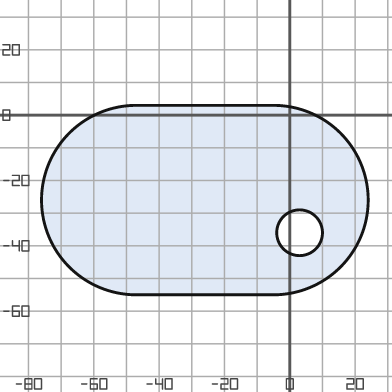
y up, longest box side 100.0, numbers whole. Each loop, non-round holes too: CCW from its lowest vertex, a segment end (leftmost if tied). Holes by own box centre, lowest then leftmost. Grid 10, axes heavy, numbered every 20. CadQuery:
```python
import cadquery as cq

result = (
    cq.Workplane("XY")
    .moveTo(-47.0, -55.0)
    .lineTo(-5.0, -55.0)
    .threePointArc((24.0, -26.0), (-5.0, 3.0))
    .lineTo(-47.0, 3.0)
    .threePointArc((-76.0, -26.0), (-47.0, -55.0))
    .close()
    .moveTo(3.0, -36.0)
    .circle(7.0)
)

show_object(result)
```